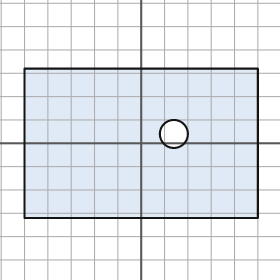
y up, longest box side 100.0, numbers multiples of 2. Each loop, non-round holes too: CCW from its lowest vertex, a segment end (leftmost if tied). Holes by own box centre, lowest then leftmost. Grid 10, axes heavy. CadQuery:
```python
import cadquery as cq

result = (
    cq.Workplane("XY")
    .moveTo(-50.0, -32.0)
    .lineTo(50.0, -32.0)
    .lineTo(50.0, 32.0)
    .lineTo(-50.0, 32.0)
    .close()
    .moveTo(14.0, 4.0)
    .circle(6.0)
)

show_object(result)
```